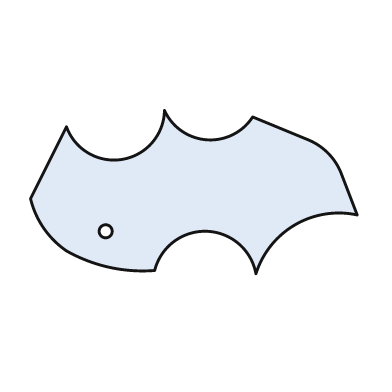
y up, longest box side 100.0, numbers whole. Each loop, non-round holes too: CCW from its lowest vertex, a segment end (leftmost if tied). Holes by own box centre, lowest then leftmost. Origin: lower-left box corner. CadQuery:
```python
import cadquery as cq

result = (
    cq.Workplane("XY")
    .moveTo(69.0, 0.0)
    .threePointArc((81.0, 15.0), (100.0, 18.0))
    .lineTo(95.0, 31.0)
    .threePointArc((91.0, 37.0), (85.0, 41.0))
    .lineTo(68.0, 48.0)
    .threePointArc((54.0, 41.0), (41.0, 50.0))
    .threePointArc((28.0, 35.0), (11.0, 45.0))
    .lineTo(0.0, 23.0)
    .threePointArc((4.0, 14.0), (11.0, 7.0))
    .threePointArc((24.0, 2.0), (38.0, 1.0))
    .threePointArc((54.0, 13.0), (69.0, 0.0))
    .close()
    .moveTo(23.0, 13.0)
    .circle(2.0)
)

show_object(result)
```